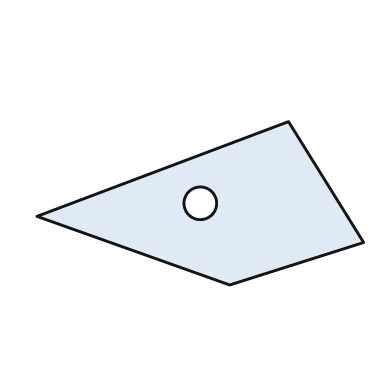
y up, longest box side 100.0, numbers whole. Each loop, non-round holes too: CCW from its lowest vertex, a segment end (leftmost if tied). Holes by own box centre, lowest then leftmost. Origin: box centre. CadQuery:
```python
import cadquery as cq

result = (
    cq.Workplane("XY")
    .moveTo(9.0, -25.0)
    .lineTo(50.0, -12.0)
    .lineTo(27.0, 25.0)
    .lineTo(-50.0, -4.0)
    .close()
    .moveTo(0.0, 0.0)
    .circle(5.0)
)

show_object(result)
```